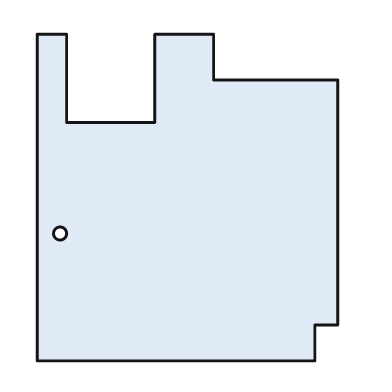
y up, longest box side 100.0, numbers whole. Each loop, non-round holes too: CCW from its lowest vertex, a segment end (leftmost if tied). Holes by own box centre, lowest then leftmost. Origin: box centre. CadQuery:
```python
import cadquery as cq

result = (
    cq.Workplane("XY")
    .moveTo(-46.0, -50.0)
    .lineTo(39.0, -50.0)
    .lineTo(39.0, -39.0)
    .lineTo(46.0, -39.0)
    .lineTo(46.0, 36.0)
    .lineTo(8.0, 36.0)
    .lineTo(8.0, 50.0)
    .lineTo(-10.0, 50.0)
    .lineTo(-10.0, 23.0)
    .lineTo(-37.0, 23.0)
    .lineTo(-37.0, 50.0)
    .lineTo(-46.0, 50.0)
    .close()
    .moveTo(-39.0, -11.0)
    .circle(2.0)
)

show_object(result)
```